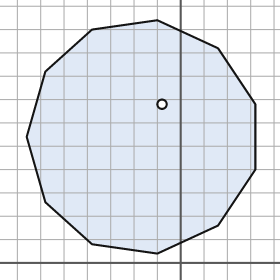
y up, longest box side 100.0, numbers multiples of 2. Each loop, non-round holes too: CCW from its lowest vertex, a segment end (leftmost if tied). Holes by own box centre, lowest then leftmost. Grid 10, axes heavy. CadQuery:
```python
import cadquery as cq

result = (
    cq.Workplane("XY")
    .moveTo(-10.0, 4.0)
    .lineTo(16.0, 16.0)
    .lineTo(32.0, 40.0)
    .lineTo(32.0, 68.0)
    .lineTo(16.0, 92.0)
    .lineTo(-10.0, 104.0)
    .lineTo(-38.0, 100.0)
    .lineTo(-58.0, 82.0)
    .lineTo(-66.0, 54.0)
    .lineTo(-58.0, 26.0)
    .lineTo(-38.0, 8.0)
    .close()
    .moveTo(-8.0, 68.0)
    .circle(2.0)
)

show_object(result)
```